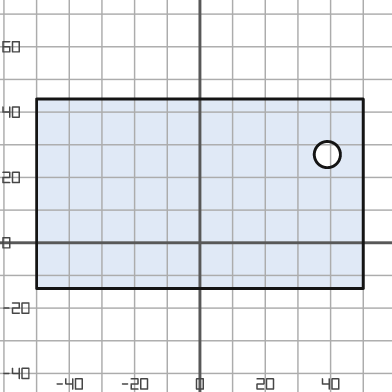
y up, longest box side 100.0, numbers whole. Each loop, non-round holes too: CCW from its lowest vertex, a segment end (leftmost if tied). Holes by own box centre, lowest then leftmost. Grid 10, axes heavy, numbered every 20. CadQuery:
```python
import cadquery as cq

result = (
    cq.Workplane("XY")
    .moveTo(-50.0, -14.0)
    .lineTo(50.0, -14.0)
    .lineTo(50.0, 44.0)
    .lineTo(-50.0, 44.0)
    .close()
    .moveTo(39.0, 27.0)
    .circle(4.0)
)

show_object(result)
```